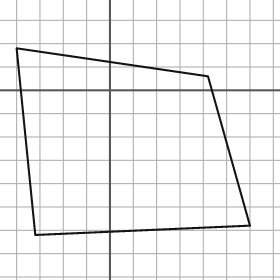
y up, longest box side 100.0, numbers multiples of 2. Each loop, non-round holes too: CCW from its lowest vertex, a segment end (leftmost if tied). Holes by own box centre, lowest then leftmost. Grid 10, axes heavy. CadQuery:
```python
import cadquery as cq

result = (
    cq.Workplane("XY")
    .moveTo(-32.0, -62.0)
    .lineTo(60.0, -58.0)
    .lineTo(42.0, 6.0)
    .lineTo(-40.0, 18.0)
    .close()
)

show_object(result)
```